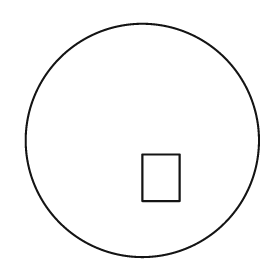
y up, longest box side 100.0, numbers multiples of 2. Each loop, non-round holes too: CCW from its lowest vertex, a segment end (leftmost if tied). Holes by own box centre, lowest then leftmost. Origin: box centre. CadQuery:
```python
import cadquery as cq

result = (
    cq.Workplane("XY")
    .moveTo(0.0, 0.0)
    .circle(50.0)
    .moveTo(0.0, -26.0)
    .lineTo(16.0, -26.0)
    .lineTo(16.0, -6.0)
    .lineTo(0.0, -6.0)
    .close()
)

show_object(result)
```